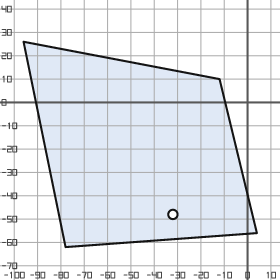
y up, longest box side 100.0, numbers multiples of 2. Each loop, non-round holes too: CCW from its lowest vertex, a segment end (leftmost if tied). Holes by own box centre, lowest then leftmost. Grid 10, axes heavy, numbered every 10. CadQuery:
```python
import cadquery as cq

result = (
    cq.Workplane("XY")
    .moveTo(-78.0, -62.0)
    .lineTo(4.0, -56.0)
    .lineTo(-12.0, 10.0)
    .lineTo(-96.0, 26.0)
    .close()
    .moveTo(-32.0, -48.0)
    .circle(2.0)
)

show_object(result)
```